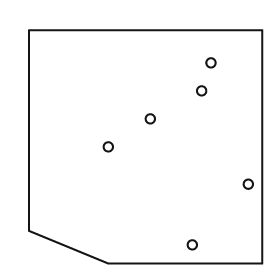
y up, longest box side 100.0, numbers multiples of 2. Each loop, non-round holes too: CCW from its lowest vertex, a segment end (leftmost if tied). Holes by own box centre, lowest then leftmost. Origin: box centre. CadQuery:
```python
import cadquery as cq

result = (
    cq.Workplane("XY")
    .moveTo(-16.0, -50.0)
    .lineTo(50.0, -50.0)
    .lineTo(50.0, 50.0)
    .lineTo(-50.0, 50.0)
    .lineTo(-50.0, -36.0)
    .close()
    .moveTo(20.0, -42.0)
    .circle(2.0)
    .moveTo(44.0, -16.0)
    .circle(2.0)
    .moveTo(-16.0, 0.0)
    .circle(2.0)
    .moveTo(2.0, 12.0)
    .circle(2.0)
    .moveTo(24.0, 24.0)
    .circle(2.0)
    .moveTo(28.0, 36.0)
    .circle(2.0)
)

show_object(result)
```